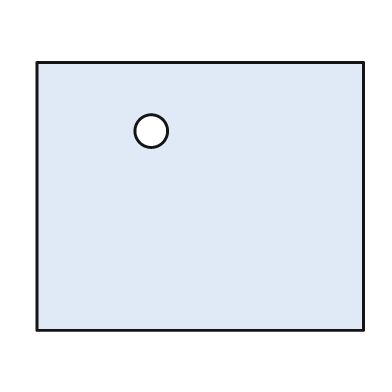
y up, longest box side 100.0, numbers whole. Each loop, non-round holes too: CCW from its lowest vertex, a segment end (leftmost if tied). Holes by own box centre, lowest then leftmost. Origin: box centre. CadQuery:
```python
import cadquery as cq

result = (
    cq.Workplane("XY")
    .moveTo(-50.0, -41.0)
    .lineTo(50.0, -41.0)
    .lineTo(50.0, 41.0)
    .lineTo(-50.0, 41.0)
    .close()
    .moveTo(-15.0, 20.0)
    .circle(5.0)
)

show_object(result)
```